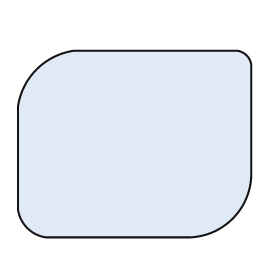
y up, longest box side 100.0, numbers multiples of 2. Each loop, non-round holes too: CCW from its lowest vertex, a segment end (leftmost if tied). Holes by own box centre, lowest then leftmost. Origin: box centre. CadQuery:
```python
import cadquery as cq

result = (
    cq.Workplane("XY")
    .moveTo(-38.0, -40.0)
    .lineTo(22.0, -40.0)
    .threePointArc((42.0, -32.0), (50.0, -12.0))
    .lineTo(50.0, 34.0)
    .threePointArc((48.0, 38.0), (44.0, 40.0))
    .lineTo(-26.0, 40.0)
    .threePointArc((-42.0, 32.0), (-50.0, 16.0))
    .lineTo(-50.0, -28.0)
    .threePointArc((-46.0, -36.0), (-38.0, -40.0))
    .close()
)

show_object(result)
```